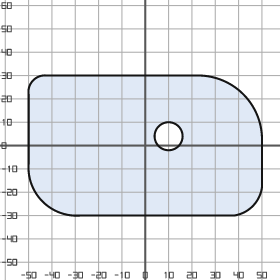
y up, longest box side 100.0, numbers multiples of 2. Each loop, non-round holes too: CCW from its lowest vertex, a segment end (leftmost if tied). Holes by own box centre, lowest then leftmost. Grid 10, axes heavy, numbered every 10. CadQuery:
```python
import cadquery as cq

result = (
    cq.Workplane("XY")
    .moveTo(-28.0, -30.0)
    .lineTo(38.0, -30.0)
    .threePointArc((46.0, -26.0), (50.0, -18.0))
    .lineTo(50.0, 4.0)
    .threePointArc((42.0, 22.0), (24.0, 30.0))
    .lineTo(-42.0, 30.0)
    .threePointArc((-48.0, 28.0), (-50.0, 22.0))
    .lineTo(-50.0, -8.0)
    .threePointArc((-44.0, -24.0), (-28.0, -30.0))
    .close()
    .moveTo(10.0, 4.0)
    .circle(6.0)
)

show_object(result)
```